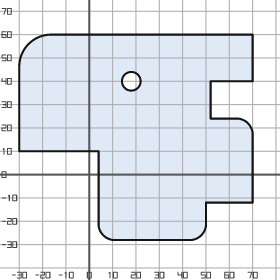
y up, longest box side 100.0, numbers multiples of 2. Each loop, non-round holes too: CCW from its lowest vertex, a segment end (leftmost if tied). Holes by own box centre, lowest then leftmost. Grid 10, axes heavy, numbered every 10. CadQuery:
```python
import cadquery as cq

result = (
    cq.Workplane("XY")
    .moveTo(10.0, -28.0)
    .lineTo(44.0, -28.0)
    .threePointArc((48.0, -26.0), (50.0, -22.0))
    .lineTo(50.0, -12.0)
    .lineTo(70.0, -12.0)
    .lineTo(70.0, 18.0)
    .threePointArc((68.0, 22.0), (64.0, 24.0))
    .lineTo(52.0, 24.0)
    .lineTo(52.0, 40.0)
    .lineTo(70.0, 40.0)
    .lineTo(70.0, 60.0)
    .lineTo(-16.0, 60.0)
    .threePointArc((-26.0, 56.0), (-30.0, 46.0))
    .lineTo(-30.0, 10.0)
    .lineTo(4.0, 10.0)
    .lineTo(4.0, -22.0)
    .threePointArc((6.0, -26.0), (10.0, -28.0))
    .close()
    .moveTo(18.0, 40.0)
    .circle(4.0)
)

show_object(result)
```